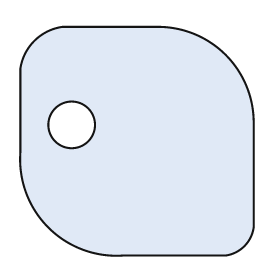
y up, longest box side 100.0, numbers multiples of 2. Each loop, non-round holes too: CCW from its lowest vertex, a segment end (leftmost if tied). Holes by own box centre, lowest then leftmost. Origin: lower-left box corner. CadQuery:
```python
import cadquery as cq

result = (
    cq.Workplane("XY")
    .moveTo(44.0, 0.0)
    .lineTo(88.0, 0.0)
    .threePointArc((96.0, 4.0), (100.0, 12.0))
    .lineTo(100.0, 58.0)
    .threePointArc((88.0, 86.0), (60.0, 98.0))
    .lineTo(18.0, 98.0)
    .threePointArc((6.0, 92.0), (0.0, 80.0))
    .lineTo(0.0, 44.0)
    .threePointArc((12.0, 12.0), (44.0, 0.0))
    .close()
    .moveTo(22.0, 56.0)
    .circle(10.0)
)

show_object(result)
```